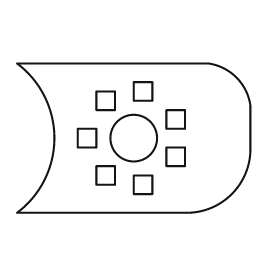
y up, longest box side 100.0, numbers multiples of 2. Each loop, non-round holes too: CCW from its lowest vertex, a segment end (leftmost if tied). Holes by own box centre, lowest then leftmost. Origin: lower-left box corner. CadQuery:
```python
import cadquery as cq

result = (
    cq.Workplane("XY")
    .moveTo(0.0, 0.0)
    .lineTo(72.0, 0.0)
    .threePointArc((92.0, 8.0), (100.0, 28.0))
    .lineTo(100.0, 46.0)
    .threePointArc((94.0, 58.0), (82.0, 64.0))
    .lineTo(0.0, 64.0)
    .threePointArc((16.0, 32.0), (0.0, 0.0))
    .close()
    .moveTo(50.0, 8.0)
    .lineTo(58.0, 8.0)
    .lineTo(58.0, 16.0)
    .lineTo(50.0, 16.0)
    .close()
    .moveTo(34.0, 12.0)
    .lineTo(42.0, 12.0)
    .lineTo(42.0, 20.0)
    .lineTo(34.0, 20.0)
    .close()
    .moveTo(64.0, 20.0)
    .lineTo(72.0, 20.0)
    .lineTo(72.0, 28.0)
    .lineTo(64.0, 28.0)
    .close()
    .moveTo(26.0, 28.0)
    .lineTo(34.0, 28.0)
    .lineTo(34.0, 36.0)
    .lineTo(26.0, 36.0)
    .close()
    .moveTo(50.0, 32.0)
    .circle(10.0)
    .moveTo(64.0, 36.0)
    .lineTo(72.0, 36.0)
    .lineTo(72.0, 44.0)
    .lineTo(64.0, 44.0)
    .close()
    .moveTo(34.0, 44.0)
    .lineTo(42.0, 44.0)
    .lineTo(42.0, 52.0)
    .lineTo(34.0, 52.0)
    .close()
    .moveTo(50.0, 48.0)
    .lineTo(58.0, 48.0)
    .lineTo(58.0, 56.0)
    .lineTo(50.0, 56.0)
    .close()
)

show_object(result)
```